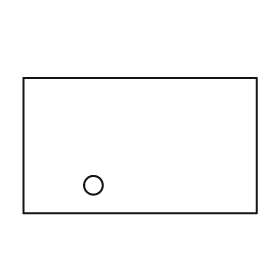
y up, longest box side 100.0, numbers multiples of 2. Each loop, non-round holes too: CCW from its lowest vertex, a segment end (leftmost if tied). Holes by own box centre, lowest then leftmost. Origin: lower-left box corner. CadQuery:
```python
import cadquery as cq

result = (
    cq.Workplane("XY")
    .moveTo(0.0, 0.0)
    .lineTo(100.0, 0.0)
    .lineTo(100.0, 58.0)
    .lineTo(0.0, 58.0)
    .close()
    .moveTo(30.0, 12.0)
    .circle(4.0)
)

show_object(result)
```